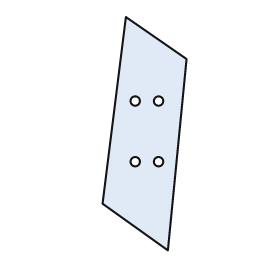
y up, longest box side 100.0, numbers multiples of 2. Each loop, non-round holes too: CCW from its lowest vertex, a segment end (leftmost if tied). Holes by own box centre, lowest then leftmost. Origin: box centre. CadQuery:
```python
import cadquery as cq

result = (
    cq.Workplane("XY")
    .moveTo(10.0, -50.0)
    .lineTo(18.0, 32.0)
    .lineTo(-8.0, 50.0)
    .lineTo(-18.0, -30.0)
    .close()
    .moveTo(-4.0, -12.0)
    .circle(2.0)
    .moveTo(6.0, -12.0)
    .circle(2.0)
    .moveTo(-4.0, 14.0)
    .circle(2.0)
    .moveTo(6.0, 14.0)
    .circle(2.0)
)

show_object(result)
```